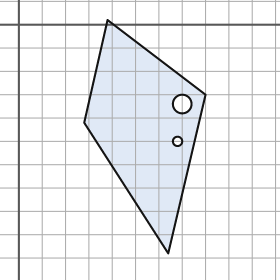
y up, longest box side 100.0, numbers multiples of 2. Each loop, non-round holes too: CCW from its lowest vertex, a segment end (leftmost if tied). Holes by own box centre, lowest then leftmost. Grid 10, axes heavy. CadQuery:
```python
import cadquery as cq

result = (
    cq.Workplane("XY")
    .moveTo(64.0, -98.0)
    .lineTo(80.0, -30.0)
    .lineTo(38.0, 2.0)
    .lineTo(28.0, -42.0)
    .close()
    .moveTo(68.0, -50.0)
    .circle(2.0)
    .moveTo(70.0, -34.0)
    .circle(4.0)
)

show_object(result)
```